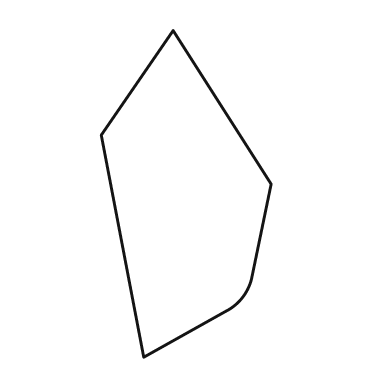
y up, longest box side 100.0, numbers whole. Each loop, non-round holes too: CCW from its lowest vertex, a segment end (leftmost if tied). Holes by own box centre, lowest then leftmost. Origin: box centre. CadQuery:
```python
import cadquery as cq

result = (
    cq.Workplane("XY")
    .moveTo(-13.0, -50.0)
    .lineTo(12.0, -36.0)
    .threePointArc((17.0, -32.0), (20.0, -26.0))
    .lineTo(26.0, 3.0)
    .lineTo(-4.0, 50.0)
    .lineTo(-26.0, 18.0)
    .close()
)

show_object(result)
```